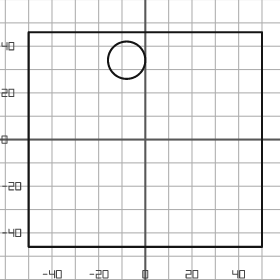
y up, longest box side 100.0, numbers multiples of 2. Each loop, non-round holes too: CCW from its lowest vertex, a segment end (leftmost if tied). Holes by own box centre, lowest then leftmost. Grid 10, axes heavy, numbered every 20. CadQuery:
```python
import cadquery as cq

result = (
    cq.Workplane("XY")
    .moveTo(-50.0, -46.0)
    .lineTo(50.0, -46.0)
    .lineTo(50.0, 46.0)
    .lineTo(-50.0, 46.0)
    .close()
    .moveTo(-8.0, 34.0)
    .circle(8.0)
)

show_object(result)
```